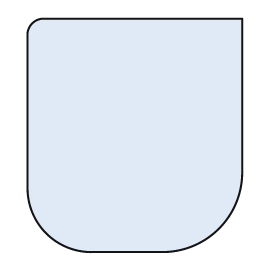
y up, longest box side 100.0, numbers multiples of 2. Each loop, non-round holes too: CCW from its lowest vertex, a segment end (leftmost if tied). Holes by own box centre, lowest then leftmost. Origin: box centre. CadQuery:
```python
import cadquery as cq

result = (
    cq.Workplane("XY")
    .moveTo(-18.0, -50.0)
    .lineTo(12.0, -50.0)
    .threePointArc((36.0, -40.0), (46.0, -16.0))
    .lineTo(46.0, 50.0)
    .lineTo(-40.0, 50.0)
    .threePointArc((-44.0, 48.0), (-46.0, 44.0))
    .lineTo(-46.0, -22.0)
    .threePointArc((-38.0, -42.0), (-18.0, -50.0))
    .close()
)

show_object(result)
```